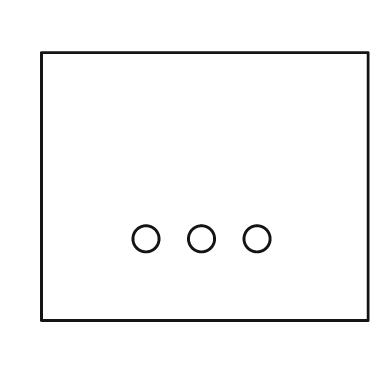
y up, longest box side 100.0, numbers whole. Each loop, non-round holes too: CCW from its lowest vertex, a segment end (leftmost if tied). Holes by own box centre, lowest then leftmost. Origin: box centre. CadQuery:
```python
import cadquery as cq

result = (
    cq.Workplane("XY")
    .moveTo(-50.0, -41.0)
    .lineTo(50.0, -41.0)
    .lineTo(50.0, 41.0)
    .lineTo(-50.0, 41.0)
    .close()
    .moveTo(-18.0, -16.0)
    .circle(4.0)
    .moveTo(-1.0, -16.0)
    .circle(4.0)
    .moveTo(16.0, -16.0)
    .circle(4.0)
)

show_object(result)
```